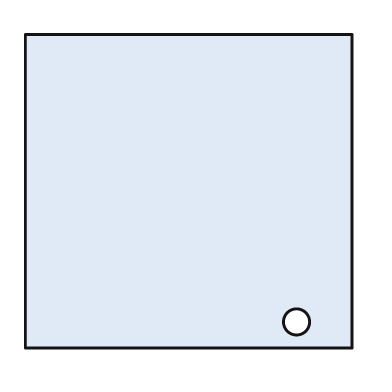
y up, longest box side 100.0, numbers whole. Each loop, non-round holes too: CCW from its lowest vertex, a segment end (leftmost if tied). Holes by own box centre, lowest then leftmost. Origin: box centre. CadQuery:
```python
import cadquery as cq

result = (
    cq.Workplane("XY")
    .moveTo(-50.0, -48.0)
    .lineTo(50.0, -48.0)
    .lineTo(50.0, 48.0)
    .lineTo(-50.0, 48.0)
    .close()
    .moveTo(33.0, -40.0)
    .circle(4.0)
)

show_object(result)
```